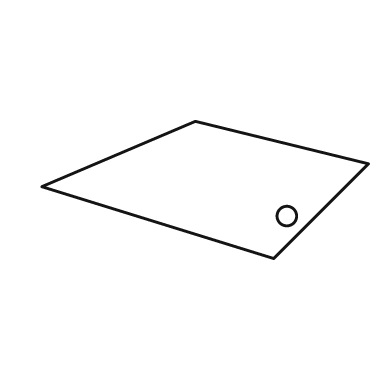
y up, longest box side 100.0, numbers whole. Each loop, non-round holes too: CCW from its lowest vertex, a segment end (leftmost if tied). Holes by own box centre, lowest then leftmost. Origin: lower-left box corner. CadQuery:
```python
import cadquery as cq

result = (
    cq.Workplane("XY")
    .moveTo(71.0, 0.0)
    .lineTo(100.0, 29.0)
    .lineTo(47.0, 42.0)
    .lineTo(0.0, 22.0)
    .close()
    .moveTo(75.0, 13.0)
    .circle(3.0)
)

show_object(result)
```